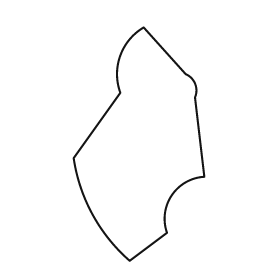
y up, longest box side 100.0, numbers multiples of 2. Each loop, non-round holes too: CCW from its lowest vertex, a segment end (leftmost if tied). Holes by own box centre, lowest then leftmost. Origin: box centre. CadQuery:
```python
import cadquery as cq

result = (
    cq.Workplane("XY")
    .moveTo(-4.0, -50.0)
    .lineTo(12.0, -38.0)
    .threePointArc((14.0, -22.0), (28.0, -14.0))
    .lineTo(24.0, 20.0)
    .threePointArc((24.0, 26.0), (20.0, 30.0))
    .lineTo(2.0, 50.0)
    .threePointArc((-8.0, 38.0), (-8.0, 22.0))
    .lineTo(-28.0, -6.0)
    .threePointArc((-20.0, -30.0), (-4.0, -50.0))
    .close()
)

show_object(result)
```